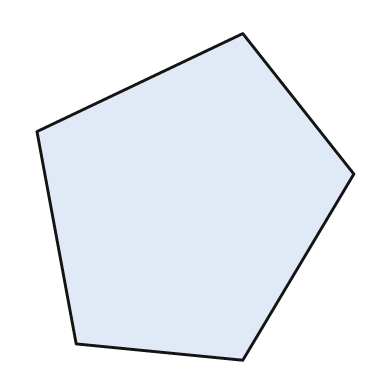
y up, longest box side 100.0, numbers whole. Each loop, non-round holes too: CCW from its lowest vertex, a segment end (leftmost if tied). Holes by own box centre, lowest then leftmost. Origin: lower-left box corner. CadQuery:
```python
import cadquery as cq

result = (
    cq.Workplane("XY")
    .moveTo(63.0, 0.0)
    .lineTo(97.0, 57.0)
    .lineTo(63.0, 100.0)
    .lineTo(0.0, 70.0)
    .lineTo(12.0, 5.0)
    .close()
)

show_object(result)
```